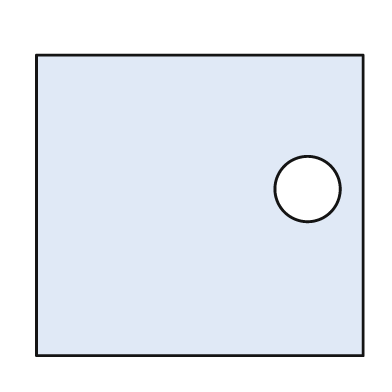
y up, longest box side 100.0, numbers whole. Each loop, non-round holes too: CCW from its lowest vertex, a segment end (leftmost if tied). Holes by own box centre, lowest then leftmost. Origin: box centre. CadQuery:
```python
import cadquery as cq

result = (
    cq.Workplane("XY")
    .moveTo(-50.0, -46.0)
    .lineTo(50.0, -46.0)
    .lineTo(50.0, 46.0)
    .lineTo(-50.0, 46.0)
    .close()
    .moveTo(33.0, 5.0)
    .circle(10.0)
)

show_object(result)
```